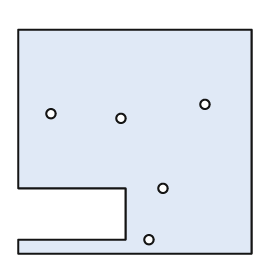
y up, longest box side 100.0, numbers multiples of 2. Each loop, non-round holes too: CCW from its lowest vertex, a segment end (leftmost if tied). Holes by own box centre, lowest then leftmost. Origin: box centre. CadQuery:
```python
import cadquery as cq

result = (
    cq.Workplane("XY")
    .moveTo(-50.0, -48.0)
    .lineTo(50.0, -48.0)
    .lineTo(50.0, 48.0)
    .lineTo(-50.0, 48.0)
    .lineTo(-50.0, -20.0)
    .lineTo(-4.0, -20.0)
    .lineTo(-4.0, -42.0)
    .lineTo(-50.0, -42.0)
    .close()
    .moveTo(6.0, -42.0)
    .circle(2.0)
    .moveTo(12.0, -20.0)
    .circle(2.0)
    .moveTo(-6.0, 10.0)
    .circle(2.0)
    .moveTo(-36.0, 12.0)
    .circle(2.0)
    .moveTo(30.0, 16.0)
    .circle(2.0)
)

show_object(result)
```